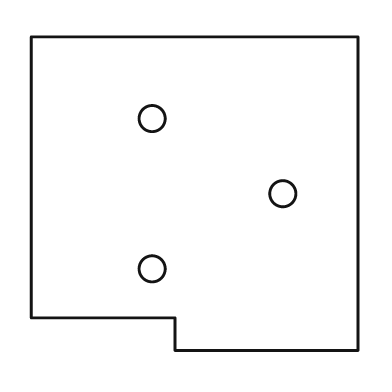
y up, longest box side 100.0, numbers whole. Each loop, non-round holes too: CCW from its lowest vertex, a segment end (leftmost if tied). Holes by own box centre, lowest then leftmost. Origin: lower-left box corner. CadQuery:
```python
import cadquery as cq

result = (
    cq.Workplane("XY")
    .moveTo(44.0, 0.0)
    .lineTo(100.0, 0.0)
    .lineTo(100.0, 96.0)
    .lineTo(0.0, 96.0)
    .lineTo(0.0, 10.0)
    .lineTo(44.0, 10.0)
    .close()
    .moveTo(37.0, 25.0)
    .circle(4.0)
    .moveTo(77.0, 48.0)
    .circle(4.0)
    .moveTo(37.0, 71.0)
    .circle(4.0)
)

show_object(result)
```